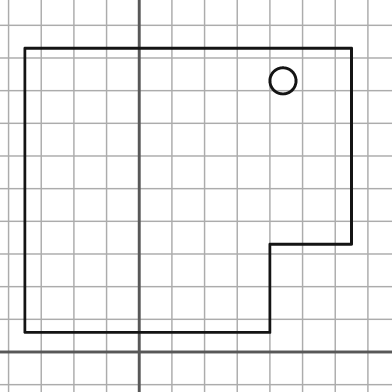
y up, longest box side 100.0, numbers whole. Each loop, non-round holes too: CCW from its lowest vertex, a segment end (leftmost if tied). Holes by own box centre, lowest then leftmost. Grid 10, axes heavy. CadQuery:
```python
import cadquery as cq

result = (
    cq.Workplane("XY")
    .moveTo(-35.0, 6.0)
    .lineTo(40.0, 6.0)
    .lineTo(40.0, 33.0)
    .lineTo(65.0, 33.0)
    .lineTo(65.0, 93.0)
    .lineTo(-35.0, 93.0)
    .close()
    .moveTo(44.0, 83.0)
    .circle(4.0)
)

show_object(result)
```